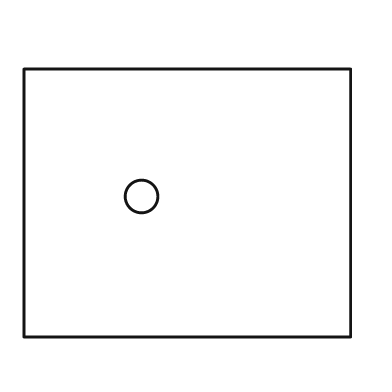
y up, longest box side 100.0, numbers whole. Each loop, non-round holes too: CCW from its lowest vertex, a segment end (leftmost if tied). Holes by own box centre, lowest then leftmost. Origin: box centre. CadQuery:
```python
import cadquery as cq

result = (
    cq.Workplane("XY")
    .moveTo(-50.0, -41.0)
    .lineTo(50.0, -41.0)
    .lineTo(50.0, 41.0)
    .lineTo(-50.0, 41.0)
    .close()
    .moveTo(-14.0, 2.0)
    .circle(5.0)
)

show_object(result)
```